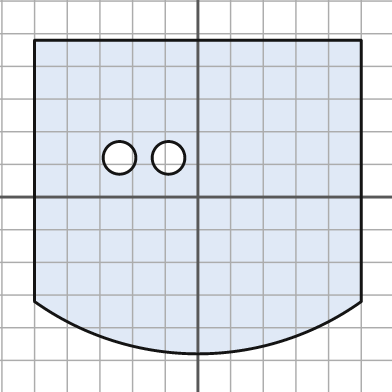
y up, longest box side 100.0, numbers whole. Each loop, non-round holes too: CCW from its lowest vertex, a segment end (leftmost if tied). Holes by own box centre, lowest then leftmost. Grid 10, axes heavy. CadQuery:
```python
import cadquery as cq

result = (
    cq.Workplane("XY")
    .moveTo(-50.0, -32.0)
    .threePointArc((0.0, -48.0), (50.0, -32.0))
    .lineTo(50.0, 48.0)
    .lineTo(-50.0, 48.0)
    .close()
    .moveTo(-24.0, 12.0)
    .circle(5.0)
    .moveTo(-9.0, 12.0)
    .circle(5.0)
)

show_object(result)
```